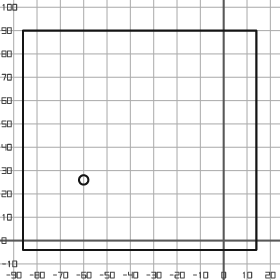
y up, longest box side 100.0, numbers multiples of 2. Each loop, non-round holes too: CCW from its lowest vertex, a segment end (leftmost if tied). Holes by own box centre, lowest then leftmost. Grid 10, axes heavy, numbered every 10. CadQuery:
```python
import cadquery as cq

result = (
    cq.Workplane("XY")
    .moveTo(-86.0, -4.0)
    .lineTo(14.0, -4.0)
    .lineTo(14.0, 90.0)
    .lineTo(-86.0, 90.0)
    .close()
    .moveTo(-60.0, 26.0)
    .circle(2.0)
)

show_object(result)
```